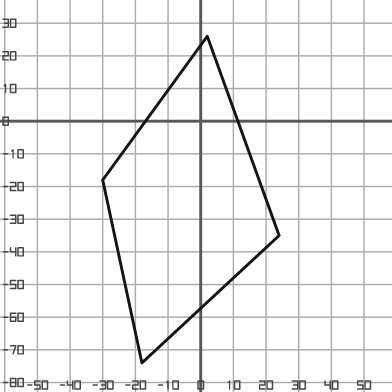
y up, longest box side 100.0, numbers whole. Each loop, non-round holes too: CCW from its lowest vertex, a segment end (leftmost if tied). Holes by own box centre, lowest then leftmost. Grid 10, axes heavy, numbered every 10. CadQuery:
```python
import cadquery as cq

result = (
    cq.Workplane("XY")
    .moveTo(-18.0, -74.0)
    .lineTo(24.0, -35.0)
    .lineTo(2.0, 26.0)
    .lineTo(-30.0, -18.0)
    .close()
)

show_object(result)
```